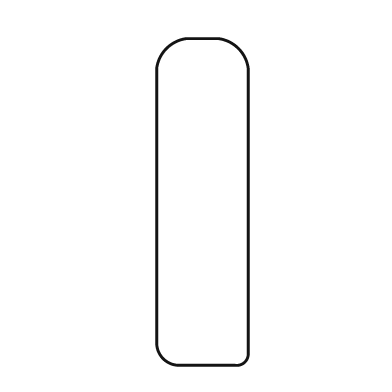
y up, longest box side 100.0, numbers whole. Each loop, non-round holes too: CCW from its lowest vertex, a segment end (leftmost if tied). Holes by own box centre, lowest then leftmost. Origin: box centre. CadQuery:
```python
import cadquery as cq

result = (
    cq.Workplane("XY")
    .moveTo(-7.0, -50.0)
    .lineTo(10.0, -50.0)
    .threePointArc((13.0, -49.0), (14.0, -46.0))
    .lineTo(14.0, 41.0)
    .threePointArc((11.0, 47.0), (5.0, 50.0))
    .lineTo(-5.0, 50.0)
    .threePointArc((-11.0, 47.0), (-14.0, 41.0))
    .lineTo(-14.0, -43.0)
    .threePointArc((-12.0, -48.0), (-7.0, -50.0))
    .close()
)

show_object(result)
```